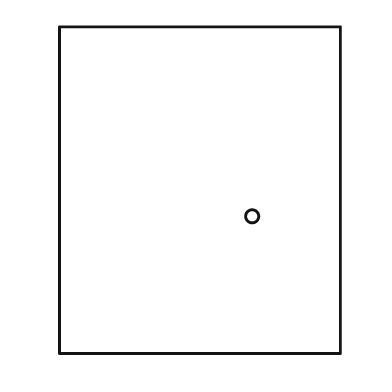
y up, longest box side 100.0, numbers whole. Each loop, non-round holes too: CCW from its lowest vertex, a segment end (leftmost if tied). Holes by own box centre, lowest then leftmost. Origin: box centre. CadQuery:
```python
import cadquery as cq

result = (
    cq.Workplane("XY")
    .moveTo(-43.0, -50.0)
    .lineTo(43.0, -50.0)
    .lineTo(43.0, 50.0)
    .lineTo(-43.0, 50.0)
    .close()
    .moveTo(16.0, -8.0)
    .circle(2.0)
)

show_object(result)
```